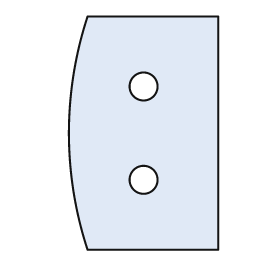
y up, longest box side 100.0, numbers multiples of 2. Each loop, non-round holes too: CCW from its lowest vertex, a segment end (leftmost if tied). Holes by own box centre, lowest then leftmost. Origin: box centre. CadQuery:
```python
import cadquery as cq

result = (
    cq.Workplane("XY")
    .moveTo(-24.0, -50.0)
    .lineTo(32.0, -50.0)
    .lineTo(32.0, 50.0)
    .lineTo(-24.0, 50.0)
    .threePointArc((-32.0, 0.0), (-24.0, -50.0))
    .close()
    .moveTo(0.0, -20.0)
    .circle(6.0)
    .moveTo(0.0, 20.0)
    .circle(6.0)
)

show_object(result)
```